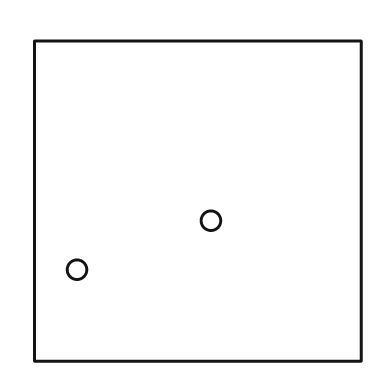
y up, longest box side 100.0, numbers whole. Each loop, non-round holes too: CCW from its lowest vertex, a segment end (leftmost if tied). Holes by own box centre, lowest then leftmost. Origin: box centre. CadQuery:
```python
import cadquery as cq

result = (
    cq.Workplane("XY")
    .moveTo(-50.0, -49.0)
    .lineTo(50.0, -49.0)
    .lineTo(50.0, 49.0)
    .lineTo(-50.0, 49.0)
    .close()
    .moveTo(-37.0, -21.0)
    .circle(3.0)
    .moveTo(4.0, -6.0)
    .circle(3.0)
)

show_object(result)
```